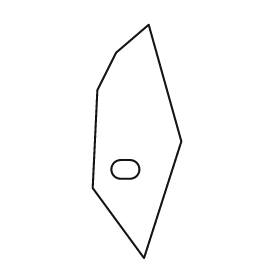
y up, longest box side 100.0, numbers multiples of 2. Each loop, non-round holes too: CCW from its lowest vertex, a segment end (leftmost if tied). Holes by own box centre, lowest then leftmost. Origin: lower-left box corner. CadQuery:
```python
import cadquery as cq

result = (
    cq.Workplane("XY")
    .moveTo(22.0, 0.0)
    .lineTo(38.0, 50.0)
    .lineTo(24.0, 100.0)
    .lineTo(10.0, 88.0)
    .lineTo(2.0, 72.0)
    .lineTo(0.0, 30.0)
    .close()
    .moveTo(12.0, 34.0)
    .lineTo(16.0, 34.0)
    .threePointArc((20.0, 38.0), (16.0, 42.0))
    .lineTo(12.0, 42.0)
    .threePointArc((8.0, 38.0), (12.0, 34.0))
    .close()
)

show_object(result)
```